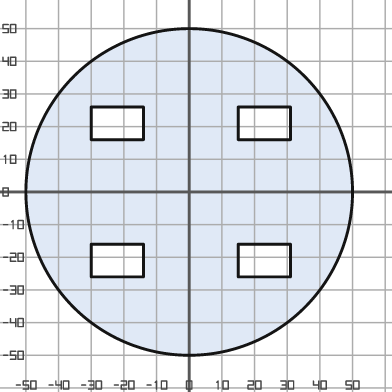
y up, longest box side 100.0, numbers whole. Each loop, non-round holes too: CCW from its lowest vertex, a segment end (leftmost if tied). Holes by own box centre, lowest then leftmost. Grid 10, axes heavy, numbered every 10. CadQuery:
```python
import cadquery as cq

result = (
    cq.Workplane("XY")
    .moveTo(0.0, 0.0)
    .circle(50.0)
    .moveTo(-30.0, -26.0)
    .lineTo(-14.0, -26.0)
    .lineTo(-14.0, -16.0)
    .lineTo(-30.0, -16.0)
    .close()
    .moveTo(15.0, -26.0)
    .lineTo(31.0, -26.0)
    .lineTo(31.0, -16.0)
    .lineTo(15.0, -16.0)
    .close()
    .moveTo(-30.0, 16.0)
    .lineTo(-14.0, 16.0)
    .lineTo(-14.0, 26.0)
    .lineTo(-30.0, 26.0)
    .close()
    .moveTo(15.0, 16.0)
    .lineTo(31.0, 16.0)
    .lineTo(31.0, 26.0)
    .lineTo(15.0, 26.0)
    .close()
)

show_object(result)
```